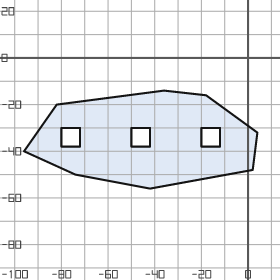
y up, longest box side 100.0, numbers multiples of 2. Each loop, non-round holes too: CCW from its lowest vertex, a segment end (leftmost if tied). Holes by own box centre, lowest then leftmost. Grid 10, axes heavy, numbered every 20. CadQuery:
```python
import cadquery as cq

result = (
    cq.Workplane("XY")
    .moveTo(-42.0, -56.0)
    .lineTo(2.0, -48.0)
    .lineTo(4.0, -32.0)
    .lineTo(-18.0, -16.0)
    .lineTo(-36.0, -14.0)
    .lineTo(-82.0, -20.0)
    .lineTo(-96.0, -40.0)
    .lineTo(-74.0, -50.0)
    .close()
    .moveTo(-80.0, -38.0)
    .lineTo(-72.0, -38.0)
    .lineTo(-72.0, -30.0)
    .lineTo(-80.0, -30.0)
    .close()
    .moveTo(-50.0, -38.0)
    .lineTo(-42.0, -38.0)
    .lineTo(-42.0, -30.0)
    .lineTo(-50.0, -30.0)
    .close()
    .moveTo(-20.0, -38.0)
    .lineTo(-12.0, -38.0)
    .lineTo(-12.0, -30.0)
    .lineTo(-20.0, -30.0)
    .close()
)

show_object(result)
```